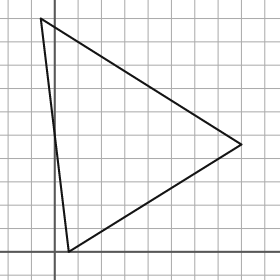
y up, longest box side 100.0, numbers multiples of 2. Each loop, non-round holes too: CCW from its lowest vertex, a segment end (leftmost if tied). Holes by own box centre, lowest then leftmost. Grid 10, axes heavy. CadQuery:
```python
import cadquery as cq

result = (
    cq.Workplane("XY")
    .moveTo(6.0, 0.0)
    .lineTo(80.0, 46.0)
    .lineTo(-6.0, 100.0)
    .close()
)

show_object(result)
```